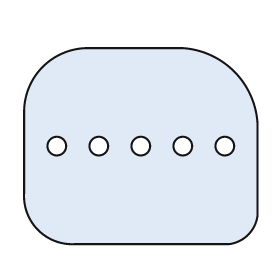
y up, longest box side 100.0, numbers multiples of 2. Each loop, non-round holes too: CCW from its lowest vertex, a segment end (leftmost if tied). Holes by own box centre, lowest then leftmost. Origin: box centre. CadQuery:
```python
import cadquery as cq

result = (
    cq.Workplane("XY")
    .moveTo(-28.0, -42.0)
    .lineTo(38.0, -42.0)
    .threePointArc((46.0, -38.0), (50.0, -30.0))
    .lineTo(50.0, 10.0)
    .threePointArc((40.0, 32.0), (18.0, 42.0))
    .lineTo(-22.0, 42.0)
    .threePointArc((-42.0, 34.0), (-50.0, 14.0))
    .lineTo(-50.0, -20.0)
    .threePointArc((-44.0, -36.0), (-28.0, -42.0))
    .close()
    .moveTo(-36.0, 0.0)
    .circle(4.0)
    .moveTo(-18.0, 0.0)
    .circle(4.0)
    .moveTo(0.0, 0.0)
    .circle(4.0)
    .moveTo(18.0, 0.0)
    .circle(4.0)
    .moveTo(36.0, 0.0)
    .circle(4.0)
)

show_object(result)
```